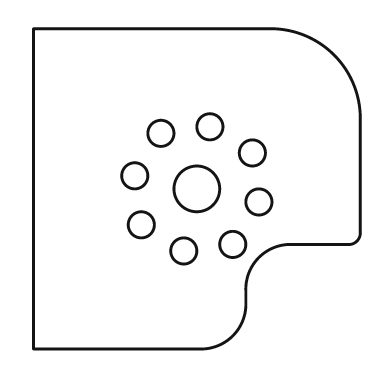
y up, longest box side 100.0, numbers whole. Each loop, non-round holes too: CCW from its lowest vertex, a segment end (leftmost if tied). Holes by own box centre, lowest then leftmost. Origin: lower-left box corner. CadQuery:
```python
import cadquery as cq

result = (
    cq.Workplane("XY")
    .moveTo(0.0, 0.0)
    .lineTo(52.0, 0.0)
    .threePointArc((61.0, 4.0), (65.0, 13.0))
    .lineTo(65.0, 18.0)
    .threePointArc((69.0, 28.0), (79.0, 32.0))
    .lineTo(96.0, 32.0)
    .threePointArc((99.0, 33.0), (100.0, 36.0))
    .lineTo(100.0, 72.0)
    .threePointArc((92.0, 90.0), (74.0, 98.0))
    .lineTo(0.0, 98.0)
    .close()
    .moveTo(46.0, 30.0)
    .circle(4.0)
    .moveTo(61.0, 32.0)
    .circle(4.0)
    .moveTo(33.0, 38.0)
    .circle(4.0)
    .moveTo(69.0, 45.0)
    .circle(4.0)
    .moveTo(50.0, 49.0)
    .circle(7.0)
    .moveTo(31.0, 53.0)
    .circle(4.0)
    .moveTo(67.0, 60.0)
    .circle(4.0)
    .moveTo(39.0, 66.0)
    .circle(4.0)
    .moveTo(54.0, 68.0)
    .circle(4.0)
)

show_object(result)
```